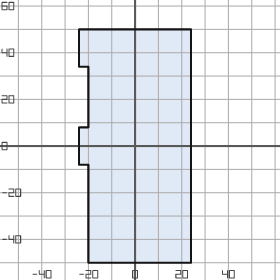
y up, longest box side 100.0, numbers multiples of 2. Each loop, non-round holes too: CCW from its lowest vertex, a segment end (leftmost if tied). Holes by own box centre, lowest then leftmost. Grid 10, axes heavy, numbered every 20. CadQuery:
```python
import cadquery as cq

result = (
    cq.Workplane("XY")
    .moveTo(-20.0, -50.0)
    .lineTo(24.0, -50.0)
    .lineTo(24.0, 50.0)
    .lineTo(-24.0, 50.0)
    .lineTo(-24.0, 34.0)
    .lineTo(-20.0, 34.0)
    .lineTo(-20.0, 8.0)
    .lineTo(-24.0, 8.0)
    .lineTo(-24.0, -8.0)
    .lineTo(-20.0, -8.0)
    .close()
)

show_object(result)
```